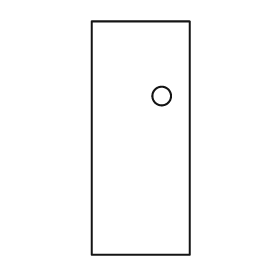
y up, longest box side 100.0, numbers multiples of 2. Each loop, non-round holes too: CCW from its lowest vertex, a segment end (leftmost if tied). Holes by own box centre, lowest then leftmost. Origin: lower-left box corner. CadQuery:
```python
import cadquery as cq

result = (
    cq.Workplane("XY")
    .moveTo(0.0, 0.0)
    .lineTo(42.0, 0.0)
    .lineTo(42.0, 100.0)
    .lineTo(0.0, 100.0)
    .close()
    .moveTo(30.0, 68.0)
    .circle(4.0)
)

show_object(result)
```